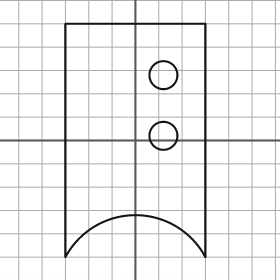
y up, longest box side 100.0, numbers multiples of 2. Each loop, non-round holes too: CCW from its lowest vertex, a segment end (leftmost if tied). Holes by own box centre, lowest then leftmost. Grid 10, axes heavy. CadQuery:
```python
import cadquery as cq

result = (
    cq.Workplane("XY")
    .moveTo(-30.0, -50.0)
    .threePointArc((0.0, -32.0), (30.0, -50.0))
    .lineTo(30.0, 50.0)
    .lineTo(-30.0, 50.0)
    .close()
    .moveTo(12.0, 2.0)
    .circle(6.0)
    .moveTo(12.0, 28.0)
    .circle(6.0)
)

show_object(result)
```